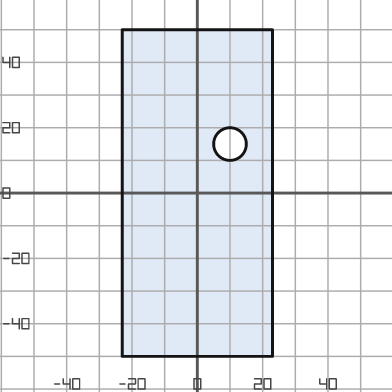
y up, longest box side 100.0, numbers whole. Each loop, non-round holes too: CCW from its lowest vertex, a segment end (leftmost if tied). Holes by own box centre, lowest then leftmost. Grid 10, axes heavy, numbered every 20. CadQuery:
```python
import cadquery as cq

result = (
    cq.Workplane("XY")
    .moveTo(-23.0, -50.0)
    .lineTo(23.0, -50.0)
    .lineTo(23.0, 50.0)
    .lineTo(-23.0, 50.0)
    .close()
    .moveTo(10.0, 15.0)
    .circle(5.0)
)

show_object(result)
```